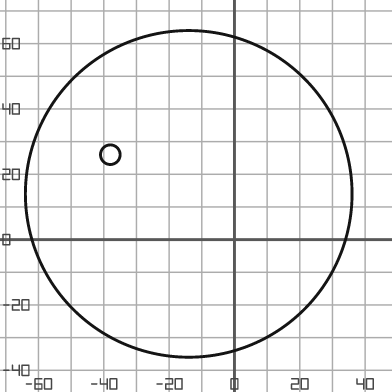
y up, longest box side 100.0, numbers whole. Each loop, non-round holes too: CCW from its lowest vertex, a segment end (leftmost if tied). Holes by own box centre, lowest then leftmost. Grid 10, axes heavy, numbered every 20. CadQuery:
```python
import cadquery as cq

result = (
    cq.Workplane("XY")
    .moveTo(-14.0, 14.0)
    .circle(50.0)
    .moveTo(-38.0, 26.0)
    .circle(3.0)
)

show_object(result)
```